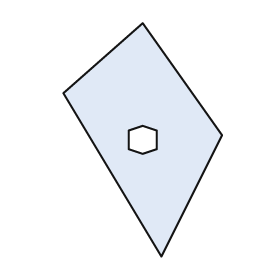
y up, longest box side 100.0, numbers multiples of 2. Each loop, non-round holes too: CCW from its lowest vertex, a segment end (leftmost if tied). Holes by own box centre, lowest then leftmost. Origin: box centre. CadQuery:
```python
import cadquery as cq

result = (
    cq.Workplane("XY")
    .moveTo(8.0, -50.0)
    .lineTo(34.0, 2.0)
    .lineTo(0.0, 50.0)
    .lineTo(-34.0, 20.0)
    .close()
    .moveTo(0.0, -6.0)
    .lineTo(6.0, -4.0)
    .lineTo(6.0, 4.0)
    .lineTo(0.0, 6.0)
    .lineTo(-6.0, 4.0)
    .lineTo(-6.0, -4.0)
    .close()
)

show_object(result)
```